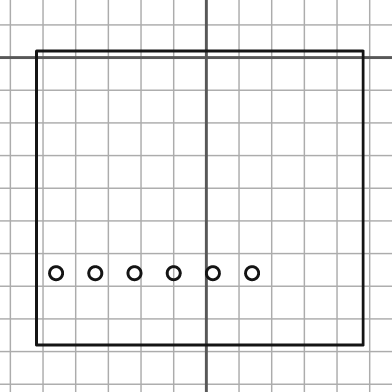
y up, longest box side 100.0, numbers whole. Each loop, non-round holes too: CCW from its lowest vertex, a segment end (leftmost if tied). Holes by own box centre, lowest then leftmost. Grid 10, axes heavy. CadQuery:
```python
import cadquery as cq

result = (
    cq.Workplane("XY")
    .moveTo(-52.0, -88.0)
    .lineTo(48.0, -88.0)
    .lineTo(48.0, 2.0)
    .lineTo(-52.0, 2.0)
    .close()
    .moveTo(-46.0, -66.0)
    .circle(2.0)
    .moveTo(-34.0, -66.0)
    .circle(2.0)
    .moveTo(-22.0, -66.0)
    .circle(2.0)
    .moveTo(-10.0, -66.0)
    .circle(2.0)
    .moveTo(2.0, -66.0)
    .circle(2.0)
    .moveTo(14.0, -66.0)
    .circle(2.0)
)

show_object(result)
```